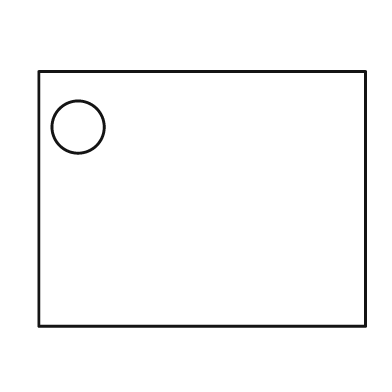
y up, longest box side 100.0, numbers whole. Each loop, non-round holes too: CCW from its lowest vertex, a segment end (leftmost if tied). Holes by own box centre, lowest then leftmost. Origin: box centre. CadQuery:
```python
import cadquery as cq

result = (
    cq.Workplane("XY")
    .moveTo(-50.0, -39.0)
    .lineTo(50.0, -39.0)
    .lineTo(50.0, 39.0)
    .lineTo(-50.0, 39.0)
    .close()
    .moveTo(-38.0, 22.0)
    .circle(8.0)
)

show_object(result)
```